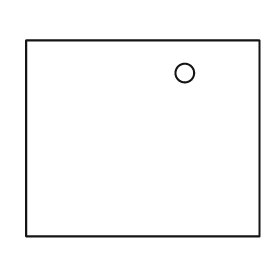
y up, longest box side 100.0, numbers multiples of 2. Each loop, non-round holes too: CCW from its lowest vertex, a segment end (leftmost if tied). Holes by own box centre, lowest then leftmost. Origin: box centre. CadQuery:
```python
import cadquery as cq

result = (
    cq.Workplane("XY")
    .moveTo(-50.0, -42.0)
    .lineTo(50.0, -42.0)
    .lineTo(50.0, 42.0)
    .lineTo(-50.0, 42.0)
    .close()
    .moveTo(18.0, 28.0)
    .circle(4.0)
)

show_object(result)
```